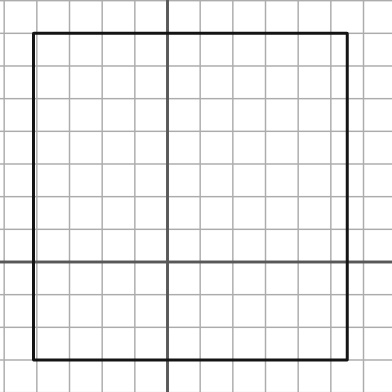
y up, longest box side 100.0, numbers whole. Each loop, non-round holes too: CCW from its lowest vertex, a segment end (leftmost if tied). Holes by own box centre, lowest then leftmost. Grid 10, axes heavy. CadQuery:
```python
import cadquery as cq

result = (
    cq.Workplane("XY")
    .moveTo(-41.0, -30.0)
    .lineTo(55.0, -30.0)
    .lineTo(55.0, 70.0)
    .lineTo(-41.0, 70.0)
    .close()
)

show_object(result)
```